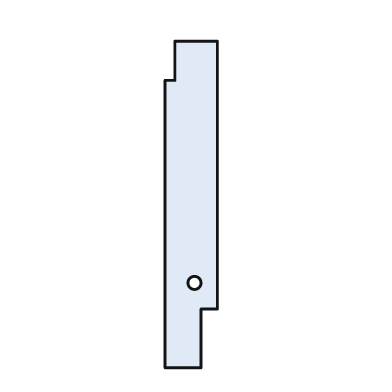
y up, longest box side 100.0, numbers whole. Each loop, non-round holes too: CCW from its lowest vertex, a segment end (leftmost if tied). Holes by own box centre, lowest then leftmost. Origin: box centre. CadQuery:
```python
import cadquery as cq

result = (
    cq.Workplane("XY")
    .moveTo(-8.0, -50.0)
    .lineTo(3.0, -50.0)
    .lineTo(3.0, -32.0)
    .lineTo(8.0, -32.0)
    .lineTo(8.0, 50.0)
    .lineTo(-5.0, 50.0)
    .lineTo(-5.0, 38.0)
    .lineTo(-8.0, 38.0)
    .close()
    .moveTo(1.0, -24.0)
    .circle(2.0)
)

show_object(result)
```